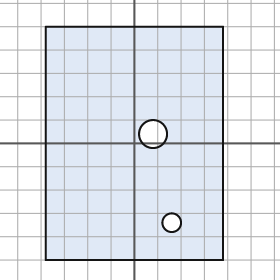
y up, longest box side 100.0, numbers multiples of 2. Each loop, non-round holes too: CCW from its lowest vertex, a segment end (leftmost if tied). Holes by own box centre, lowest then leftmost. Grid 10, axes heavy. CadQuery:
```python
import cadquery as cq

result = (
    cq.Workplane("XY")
    .moveTo(-38.0, -50.0)
    .lineTo(38.0, -50.0)
    .lineTo(38.0, 50.0)
    .lineTo(-38.0, 50.0)
    .close()
    .moveTo(16.0, -34.0)
    .circle(4.0)
    .moveTo(8.0, 4.0)
    .circle(6.0)
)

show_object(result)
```